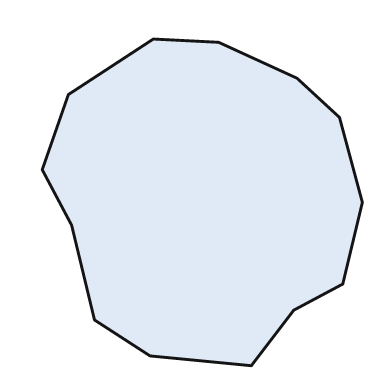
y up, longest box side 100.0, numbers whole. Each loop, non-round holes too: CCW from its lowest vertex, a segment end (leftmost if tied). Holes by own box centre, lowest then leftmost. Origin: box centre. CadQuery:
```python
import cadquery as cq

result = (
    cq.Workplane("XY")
    .moveTo(15.0, -50.0)
    .lineTo(28.0, -33.0)
    .lineTo(43.0, -25.0)
    .lineTo(49.0, 0.0)
    .lineTo(42.0, 26.0)
    .lineTo(29.0, 38.0)
    .lineTo(5.0, 49.0)
    .lineTo(-15.0, 50.0)
    .lineTo(-41.0, 33.0)
    .lineTo(-49.0, 10.0)
    .lineTo(-40.0, -7.0)
    .lineTo(-33.0, -36.0)
    .lineTo(-16.0, -47.0)
    .close()
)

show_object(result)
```